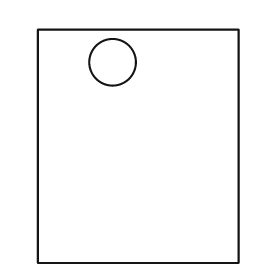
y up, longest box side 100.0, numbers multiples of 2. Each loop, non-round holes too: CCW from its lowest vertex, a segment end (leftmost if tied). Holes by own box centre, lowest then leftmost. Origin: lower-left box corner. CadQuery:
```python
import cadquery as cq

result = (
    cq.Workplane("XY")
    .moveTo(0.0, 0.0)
    .lineTo(86.0, 0.0)
    .lineTo(86.0, 100.0)
    .lineTo(0.0, 100.0)
    .close()
    .moveTo(32.0, 86.0)
    .circle(10.0)
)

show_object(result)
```